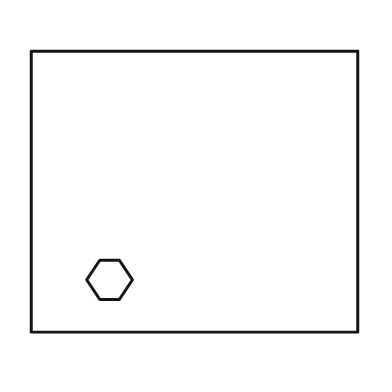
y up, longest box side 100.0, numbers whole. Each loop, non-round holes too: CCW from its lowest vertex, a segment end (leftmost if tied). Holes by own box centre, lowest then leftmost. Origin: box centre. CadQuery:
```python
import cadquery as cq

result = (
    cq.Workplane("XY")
    .moveTo(-50.0, -43.0)
    .lineTo(50.0, -43.0)
    .lineTo(50.0, 43.0)
    .lineTo(-50.0, 43.0)
    .close()
    .moveTo(-29.0, -33.0)
    .lineTo(-23.0, -33.0)
    .lineTo(-19.0, -27.0)
    .lineTo(-23.0, -21.0)
    .lineTo(-29.0, -21.0)
    .lineTo(-33.0, -27.0)
    .close()
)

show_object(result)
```